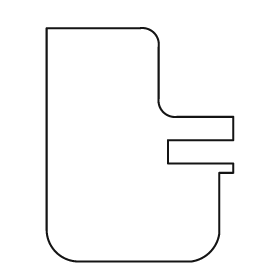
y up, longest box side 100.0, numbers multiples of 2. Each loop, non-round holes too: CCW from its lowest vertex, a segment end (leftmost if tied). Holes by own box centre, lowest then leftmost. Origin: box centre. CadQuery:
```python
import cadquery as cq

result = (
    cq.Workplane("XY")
    .moveTo(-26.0, -50.0)
    .lineTo(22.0, -50.0)
    .threePointArc((30.0, -46.0), (34.0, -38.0))
    .lineTo(34.0, -12.0)
    .lineTo(40.0, -12.0)
    .lineTo(40.0, -8.0)
    .lineTo(12.0, -8.0)
    .lineTo(12.0, 2.0)
    .lineTo(40.0, 2.0)
    .lineTo(40.0, 12.0)
    .lineTo(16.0, 12.0)
    .threePointArc((10.0, 14.0), (8.0, 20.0))
    .lineTo(8.0, 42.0)
    .threePointArc((6.0, 48.0), (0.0, 50.0))
    .lineTo(-40.0, 50.0)
    .lineTo(-40.0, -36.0)
    .threePointArc((-36.0, -46.0), (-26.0, -50.0))
    .close()
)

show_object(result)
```